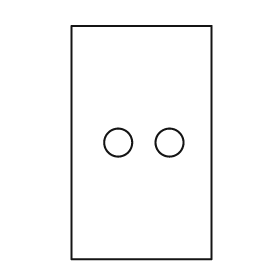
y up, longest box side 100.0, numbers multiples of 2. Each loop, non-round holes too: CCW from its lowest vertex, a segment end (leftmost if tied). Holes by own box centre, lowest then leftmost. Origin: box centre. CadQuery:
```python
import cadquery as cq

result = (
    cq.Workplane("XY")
    .moveTo(-30.0, -50.0)
    .lineTo(30.0, -50.0)
    .lineTo(30.0, 50.0)
    .lineTo(-30.0, 50.0)
    .close()
    .moveTo(-10.0, 0.0)
    .circle(6.0)
    .moveTo(12.0, 0.0)
    .circle(6.0)
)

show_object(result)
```